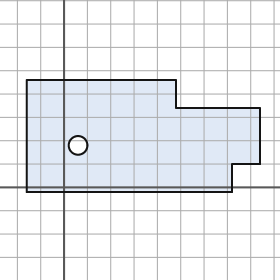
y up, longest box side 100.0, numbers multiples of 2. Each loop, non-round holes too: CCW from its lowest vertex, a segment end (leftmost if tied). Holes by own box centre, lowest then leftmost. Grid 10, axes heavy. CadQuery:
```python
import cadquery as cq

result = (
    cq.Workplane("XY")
    .moveTo(-16.0, -2.0)
    .lineTo(72.0, -2.0)
    .lineTo(72.0, 10.0)
    .lineTo(84.0, 10.0)
    .lineTo(84.0, 34.0)
    .lineTo(48.0, 34.0)
    .lineTo(48.0, 46.0)
    .lineTo(-16.0, 46.0)
    .close()
    .moveTo(6.0, 18.0)
    .circle(4.0)
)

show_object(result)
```